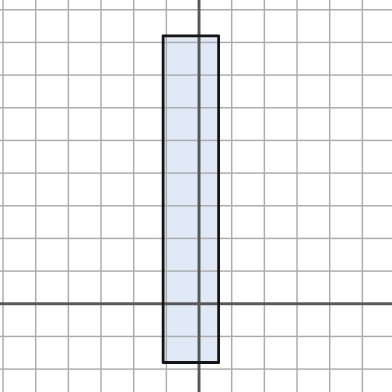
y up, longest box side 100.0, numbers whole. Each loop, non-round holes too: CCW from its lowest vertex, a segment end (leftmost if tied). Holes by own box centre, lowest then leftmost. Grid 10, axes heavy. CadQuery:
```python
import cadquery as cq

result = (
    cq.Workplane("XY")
    .moveTo(-11.0, -18.0)
    .lineTo(6.0, -18.0)
    .lineTo(6.0, 82.0)
    .lineTo(-11.0, 82.0)
    .close()
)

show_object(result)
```